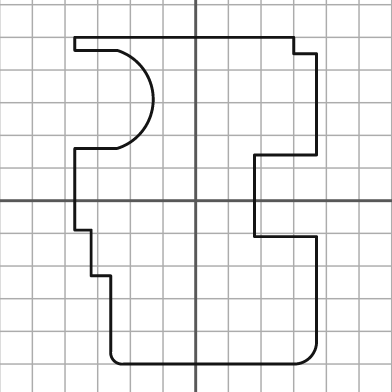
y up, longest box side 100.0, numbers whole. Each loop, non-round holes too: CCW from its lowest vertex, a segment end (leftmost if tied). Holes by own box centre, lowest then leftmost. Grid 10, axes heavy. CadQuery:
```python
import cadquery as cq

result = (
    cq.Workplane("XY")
    .moveTo(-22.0, -50.0)
    .lineTo(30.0, -50.0)
    .threePointArc((35.0, -48.0), (37.0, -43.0))
    .lineTo(37.0, -11.0)
    .lineTo(18.0, -11.0)
    .lineTo(18.0, 14.0)
    .lineTo(37.0, 14.0)
    .lineTo(37.0, 45.0)
    .lineTo(30.0, 45.0)
    .lineTo(30.0, 50.0)
    .lineTo(-37.0, 50.0)
    .lineTo(-37.0, 46.0)
    .lineTo(-24.0, 46.0)
    .threePointArc((-13.0, 31.0), (-24.0, 16.0))
    .lineTo(-37.0, 16.0)
    .lineTo(-37.0, -9.0)
    .lineTo(-32.0, -9.0)
    .lineTo(-32.0, -23.0)
    .lineTo(-26.0, -23.0)
    .lineTo(-26.0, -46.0)
    .threePointArc((-25.0, -49.0), (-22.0, -50.0))
    .close()
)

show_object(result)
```